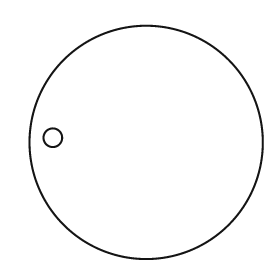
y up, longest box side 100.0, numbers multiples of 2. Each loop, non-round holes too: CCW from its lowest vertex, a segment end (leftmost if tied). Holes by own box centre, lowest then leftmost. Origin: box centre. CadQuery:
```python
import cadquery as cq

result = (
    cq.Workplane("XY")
    .moveTo(0.0, 0.0)
    .circle(50.0)
    .moveTo(-40.0, 2.0)
    .circle(4.0)
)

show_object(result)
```